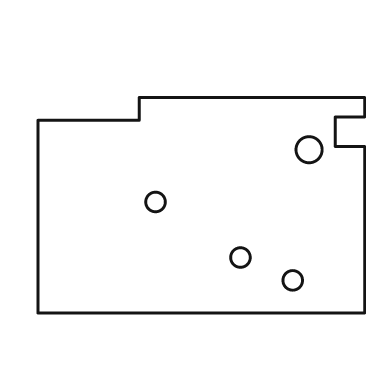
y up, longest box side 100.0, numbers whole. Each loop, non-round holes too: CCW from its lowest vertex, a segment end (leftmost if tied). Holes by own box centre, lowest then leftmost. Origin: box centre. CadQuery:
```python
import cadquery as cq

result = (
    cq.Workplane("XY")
    .moveTo(-50.0, -33.0)
    .lineTo(50.0, -33.0)
    .lineTo(50.0, 18.0)
    .lineTo(41.0, 18.0)
    .lineTo(41.0, 27.0)
    .lineTo(50.0, 27.0)
    .lineTo(50.0, 33.0)
    .lineTo(-19.0, 33.0)
    .lineTo(-19.0, 26.0)
    .lineTo(-50.0, 26.0)
    .close()
    .moveTo(28.0, -23.0)
    .circle(3.0)
    .moveTo(12.0, -16.0)
    .circle(3.0)
    .moveTo(-14.0, 1.0)
    .circle(3.0)
    .moveTo(33.0, 17.0)
    .circle(4.0)
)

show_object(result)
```